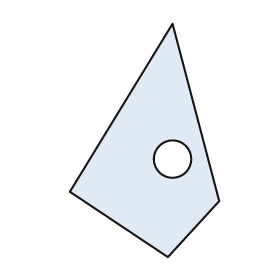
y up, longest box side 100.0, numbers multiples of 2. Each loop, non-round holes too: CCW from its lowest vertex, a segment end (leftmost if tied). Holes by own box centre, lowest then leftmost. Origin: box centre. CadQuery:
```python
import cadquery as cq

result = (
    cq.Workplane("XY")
    .moveTo(10.0, -50.0)
    .lineTo(32.0, -26.0)
    .lineTo(12.0, 50.0)
    .lineTo(-32.0, -22.0)
    .close()
    .moveTo(12.0, -8.0)
    .circle(8.0)
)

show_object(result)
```